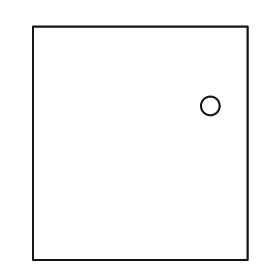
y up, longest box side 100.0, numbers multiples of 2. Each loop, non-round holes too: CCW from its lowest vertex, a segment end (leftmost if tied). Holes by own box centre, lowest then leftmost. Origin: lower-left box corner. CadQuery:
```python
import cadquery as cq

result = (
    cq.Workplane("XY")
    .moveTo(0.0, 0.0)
    .lineTo(92.0, 0.0)
    .lineTo(92.0, 100.0)
    .lineTo(0.0, 100.0)
    .close()
    .moveTo(76.0, 66.0)
    .circle(4.0)
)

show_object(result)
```